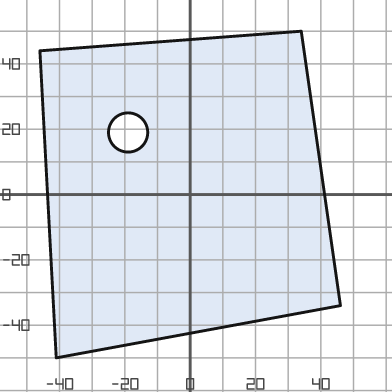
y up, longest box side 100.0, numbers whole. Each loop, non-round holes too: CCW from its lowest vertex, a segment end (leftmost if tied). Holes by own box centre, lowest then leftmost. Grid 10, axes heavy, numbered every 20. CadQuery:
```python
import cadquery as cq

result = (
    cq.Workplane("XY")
    .moveTo(-41.0, -50.0)
    .lineTo(46.0, -34.0)
    .lineTo(34.0, 50.0)
    .lineTo(-46.0, 44.0)
    .close()
    .moveTo(-19.0, 19.0)
    .circle(6.0)
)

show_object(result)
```